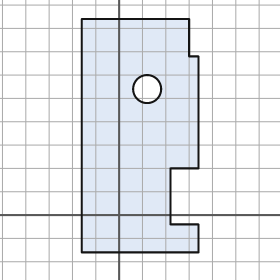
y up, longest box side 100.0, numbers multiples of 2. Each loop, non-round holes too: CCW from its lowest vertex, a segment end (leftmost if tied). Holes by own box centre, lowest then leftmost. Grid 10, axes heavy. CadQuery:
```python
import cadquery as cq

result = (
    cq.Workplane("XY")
    .moveTo(-16.0, -16.0)
    .lineTo(34.0, -16.0)
    .lineTo(34.0, -4.0)
    .lineTo(22.0, -4.0)
    .lineTo(22.0, 20.0)
    .lineTo(34.0, 20.0)
    .lineTo(34.0, 68.0)
    .lineTo(30.0, 68.0)
    .lineTo(30.0, 84.0)
    .lineTo(-16.0, 84.0)
    .close()
    .moveTo(12.0, 54.0)
    .circle(6.0)
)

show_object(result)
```